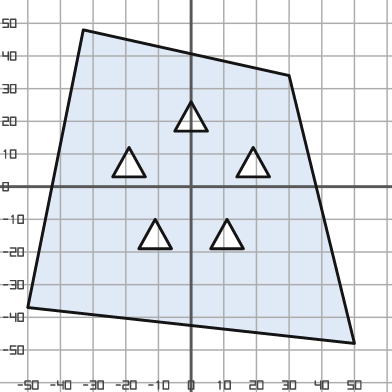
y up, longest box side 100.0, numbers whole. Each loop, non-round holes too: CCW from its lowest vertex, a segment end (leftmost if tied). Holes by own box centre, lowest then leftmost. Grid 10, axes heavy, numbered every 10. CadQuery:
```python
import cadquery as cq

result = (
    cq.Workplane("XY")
    .moveTo(50.0, -48.0)
    .lineTo(30.0, 34.0)
    .lineTo(-33.0, 48.0)
    .lineTo(-50.0, -37.0)
    .close()
    .moveTo(-16.0, -19.0)
    .lineTo(-6.0, -19.0)
    .lineTo(-11.0, -10.0)
    .close()
    .moveTo(6.0, -19.0)
    .lineTo(16.0, -19.0)
    .lineTo(11.0, -10.0)
    .close()
    .moveTo(-24.0, 3.0)
    .lineTo(-14.0, 3.0)
    .lineTo(-19.0, 12.0)
    .close()
    .moveTo(14.0, 3.0)
    .lineTo(24.0, 3.0)
    .lineTo(19.0, 12.0)
    .close()
    .moveTo(-5.0, 17.0)
    .lineTo(5.0, 17.0)
    .lineTo(0.0, 26.0)
    .close()
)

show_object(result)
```